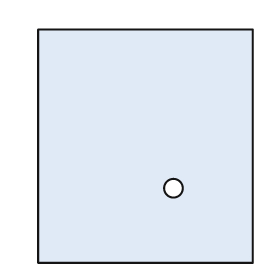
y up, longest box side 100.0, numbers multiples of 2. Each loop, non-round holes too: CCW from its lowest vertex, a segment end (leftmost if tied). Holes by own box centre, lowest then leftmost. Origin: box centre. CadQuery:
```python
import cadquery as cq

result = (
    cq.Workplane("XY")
    .moveTo(-46.0, -50.0)
    .lineTo(46.0, -50.0)
    .lineTo(46.0, 50.0)
    .lineTo(-46.0, 50.0)
    .close()
    .moveTo(12.0, -18.0)
    .circle(4.0)
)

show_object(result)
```